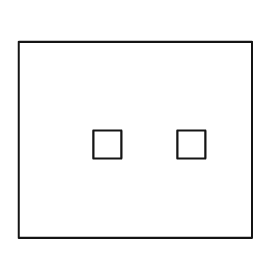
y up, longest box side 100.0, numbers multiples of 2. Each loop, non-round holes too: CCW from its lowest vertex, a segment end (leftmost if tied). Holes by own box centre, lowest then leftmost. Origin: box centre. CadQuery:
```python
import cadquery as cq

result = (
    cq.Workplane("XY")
    .moveTo(-50.0, -42.0)
    .lineTo(50.0, -42.0)
    .lineTo(50.0, 42.0)
    .lineTo(-50.0, 42.0)
    .close()
    .moveTo(-18.0, -8.0)
    .lineTo(-6.0, -8.0)
    .lineTo(-6.0, 4.0)
    .lineTo(-18.0, 4.0)
    .close()
    .moveTo(18.0, -8.0)
    .lineTo(30.0, -8.0)
    .lineTo(30.0, 4.0)
    .lineTo(18.0, 4.0)
    .close()
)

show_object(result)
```